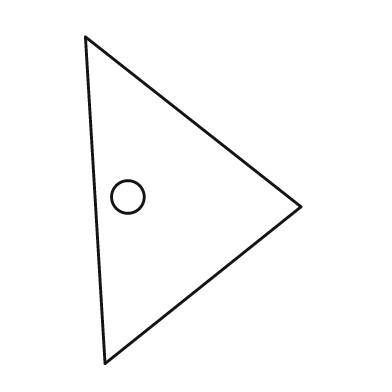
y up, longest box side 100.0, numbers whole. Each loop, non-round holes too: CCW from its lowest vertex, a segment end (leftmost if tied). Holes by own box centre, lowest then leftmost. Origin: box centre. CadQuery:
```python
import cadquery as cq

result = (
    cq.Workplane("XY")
    .moveTo(-27.0, -50.0)
    .lineTo(33.0, -2.0)
    .lineTo(-33.0, 50.0)
    .close()
    .moveTo(-20.0, 1.0)
    .circle(5.0)
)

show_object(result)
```